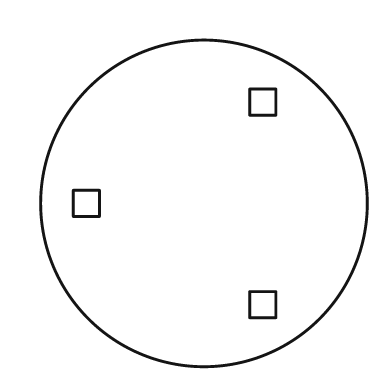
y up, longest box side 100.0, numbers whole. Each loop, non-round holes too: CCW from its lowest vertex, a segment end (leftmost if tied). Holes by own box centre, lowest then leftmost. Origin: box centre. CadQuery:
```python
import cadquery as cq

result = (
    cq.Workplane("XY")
    .moveTo(0.0, 0.0)
    .circle(50.0)
    .moveTo(14.0, -35.0)
    .lineTo(22.0, -35.0)
    .lineTo(22.0, -27.0)
    .lineTo(14.0, -27.0)
    .close()
    .moveTo(-40.0, -4.0)
    .lineTo(-32.0, -4.0)
    .lineTo(-32.0, 4.0)
    .lineTo(-40.0, 4.0)
    .close()
    .moveTo(14.0, 27.0)
    .lineTo(22.0, 27.0)
    .lineTo(22.0, 35.0)
    .lineTo(14.0, 35.0)
    .close()
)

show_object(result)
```